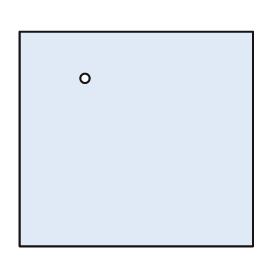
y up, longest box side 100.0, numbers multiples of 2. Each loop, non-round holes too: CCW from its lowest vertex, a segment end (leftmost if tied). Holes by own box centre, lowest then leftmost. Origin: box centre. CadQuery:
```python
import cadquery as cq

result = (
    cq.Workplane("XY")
    .moveTo(-50.0, -46.0)
    .lineTo(50.0, -46.0)
    .lineTo(50.0, 46.0)
    .lineTo(-50.0, 46.0)
    .close()
    .moveTo(-22.0, 26.0)
    .circle(2.0)
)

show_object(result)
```